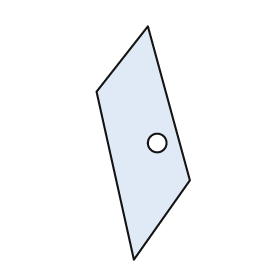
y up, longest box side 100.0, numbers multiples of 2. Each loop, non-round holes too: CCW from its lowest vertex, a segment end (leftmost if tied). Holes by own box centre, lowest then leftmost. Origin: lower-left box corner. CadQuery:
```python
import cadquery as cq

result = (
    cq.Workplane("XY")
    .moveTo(16.0, 0.0)
    .lineTo(40.0, 34.0)
    .lineTo(22.0, 100.0)
    .lineTo(0.0, 72.0)
    .close()
    .moveTo(26.0, 50.0)
    .circle(4.0)
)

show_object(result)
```